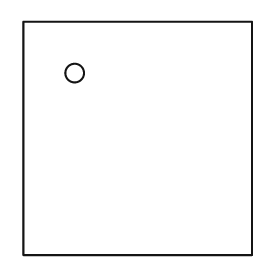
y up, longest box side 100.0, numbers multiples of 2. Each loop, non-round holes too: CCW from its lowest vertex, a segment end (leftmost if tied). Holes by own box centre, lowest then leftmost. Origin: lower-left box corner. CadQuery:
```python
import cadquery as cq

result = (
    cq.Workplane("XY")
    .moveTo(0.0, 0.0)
    .lineTo(98.0, 0.0)
    .lineTo(98.0, 100.0)
    .lineTo(0.0, 100.0)
    .close()
    .moveTo(22.0, 78.0)
    .circle(4.0)
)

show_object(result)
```